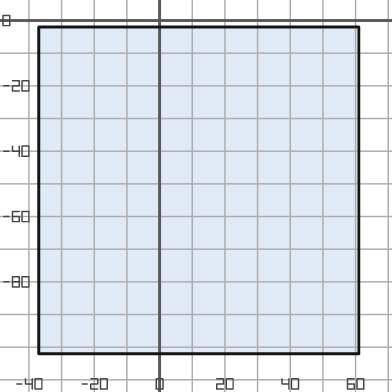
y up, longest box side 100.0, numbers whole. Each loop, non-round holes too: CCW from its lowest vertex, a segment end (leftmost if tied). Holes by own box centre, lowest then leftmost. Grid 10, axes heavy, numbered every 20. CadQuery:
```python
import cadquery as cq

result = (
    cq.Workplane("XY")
    .moveTo(-37.0, -102.0)
    .lineTo(61.0, -102.0)
    .lineTo(61.0, -2.0)
    .lineTo(-37.0, -2.0)
    .close()
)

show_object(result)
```